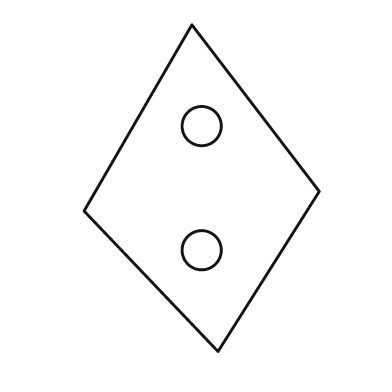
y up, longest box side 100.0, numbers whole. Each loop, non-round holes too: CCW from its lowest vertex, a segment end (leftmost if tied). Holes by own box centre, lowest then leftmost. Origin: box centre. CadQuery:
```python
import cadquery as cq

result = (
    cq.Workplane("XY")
    .moveTo(5.0, -50.0)
    .lineTo(36.0, -1.0)
    .lineTo(-3.0, 50.0)
    .lineTo(-36.0, -7.0)
    .close()
    .moveTo(0.0, -19.0)
    .circle(6.0)
    .moveTo(0.0, 19.0)
    .circle(6.0)
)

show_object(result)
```